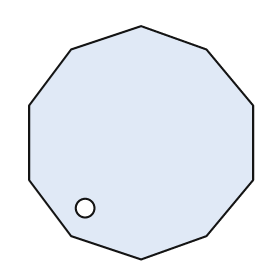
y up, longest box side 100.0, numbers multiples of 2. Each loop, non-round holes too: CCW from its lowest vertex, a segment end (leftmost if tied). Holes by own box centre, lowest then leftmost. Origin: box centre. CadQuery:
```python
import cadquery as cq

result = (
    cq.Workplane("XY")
    .moveTo(0.0, -50.0)
    .lineTo(28.0, -40.0)
    .lineTo(48.0, -16.0)
    .lineTo(48.0, 16.0)
    .lineTo(28.0, 40.0)
    .lineTo(0.0, 50.0)
    .lineTo(-30.0, 40.0)
    .lineTo(-48.0, 16.0)
    .lineTo(-48.0, -16.0)
    .lineTo(-30.0, -40.0)
    .close()
    .moveTo(-24.0, -28.0)
    .circle(4.0)
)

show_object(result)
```